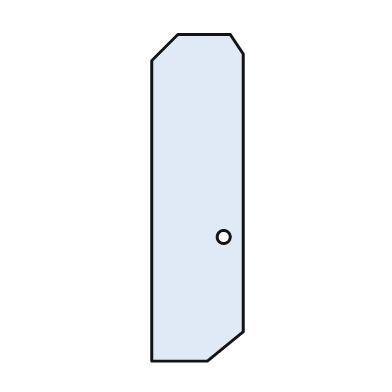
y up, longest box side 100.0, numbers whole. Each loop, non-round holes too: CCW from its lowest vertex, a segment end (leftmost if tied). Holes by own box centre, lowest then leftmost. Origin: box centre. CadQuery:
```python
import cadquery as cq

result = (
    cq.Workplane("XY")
    .moveTo(-14.0, -50.0)
    .lineTo(3.0, -50.0)
    .lineTo(14.0, -41.0)
    .lineTo(14.0, 44.0)
    .lineTo(10.0, 50.0)
    .lineTo(-6.0, 50.0)
    .lineTo(-14.0, 42.0)
    .close()
    .moveTo(8.0, -12.0)
    .circle(2.0)
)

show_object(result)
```